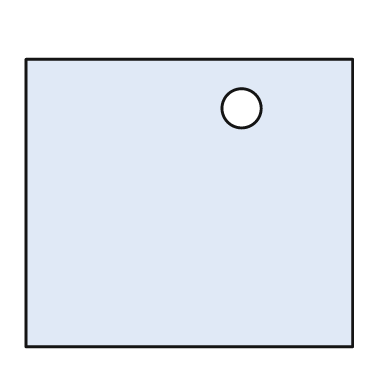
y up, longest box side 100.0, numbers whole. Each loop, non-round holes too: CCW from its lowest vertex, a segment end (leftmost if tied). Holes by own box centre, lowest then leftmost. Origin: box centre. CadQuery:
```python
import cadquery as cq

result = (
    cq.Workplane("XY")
    .moveTo(-50.0, -44.0)
    .lineTo(50.0, -44.0)
    .lineTo(50.0, 44.0)
    .lineTo(-50.0, 44.0)
    .close()
    .moveTo(16.0, 29.0)
    .circle(6.0)
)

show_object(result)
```